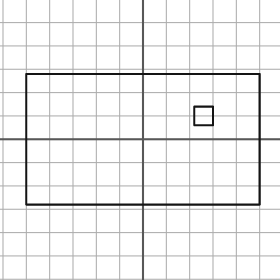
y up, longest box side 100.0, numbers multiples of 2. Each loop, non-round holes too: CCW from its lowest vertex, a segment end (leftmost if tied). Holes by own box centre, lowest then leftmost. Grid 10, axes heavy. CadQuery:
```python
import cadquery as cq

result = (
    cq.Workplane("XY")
    .moveTo(-50.0, -28.0)
    .lineTo(50.0, -28.0)
    .lineTo(50.0, 28.0)
    .lineTo(-50.0, 28.0)
    .close()
    .moveTo(22.0, 6.0)
    .lineTo(30.0, 6.0)
    .lineTo(30.0, 14.0)
    .lineTo(22.0, 14.0)
    .close()
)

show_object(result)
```